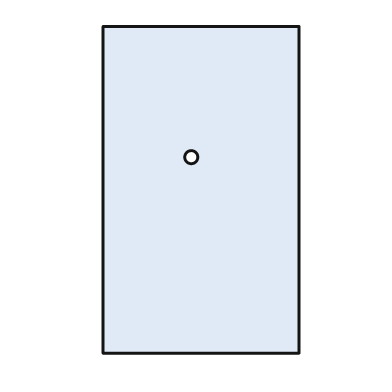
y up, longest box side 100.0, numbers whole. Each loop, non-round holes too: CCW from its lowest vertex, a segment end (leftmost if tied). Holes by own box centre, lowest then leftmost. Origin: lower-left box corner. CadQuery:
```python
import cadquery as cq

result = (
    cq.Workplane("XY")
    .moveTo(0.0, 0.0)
    .lineTo(60.0, 0.0)
    .lineTo(60.0, 100.0)
    .lineTo(0.0, 100.0)
    .close()
    .moveTo(27.0, 60.0)
    .circle(2.0)
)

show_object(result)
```